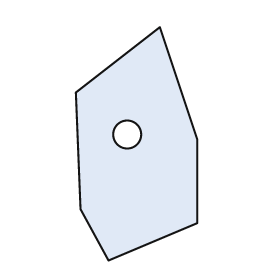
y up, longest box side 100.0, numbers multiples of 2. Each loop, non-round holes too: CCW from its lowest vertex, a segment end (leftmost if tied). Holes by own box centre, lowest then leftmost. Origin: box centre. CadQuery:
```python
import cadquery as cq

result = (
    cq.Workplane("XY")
    .moveTo(-12.0, -50.0)
    .lineTo(26.0, -34.0)
    .lineTo(26.0, 2.0)
    .lineTo(10.0, 50.0)
    .lineTo(-26.0, 22.0)
    .lineTo(-24.0, -28.0)
    .close()
    .moveTo(-4.0, 4.0)
    .circle(6.0)
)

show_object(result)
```